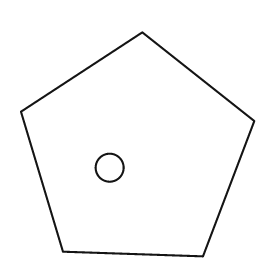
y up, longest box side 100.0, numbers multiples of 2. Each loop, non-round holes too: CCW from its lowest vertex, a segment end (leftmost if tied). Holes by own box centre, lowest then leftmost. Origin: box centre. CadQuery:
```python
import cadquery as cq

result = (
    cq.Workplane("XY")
    .moveTo(28.0, -48.0)
    .lineTo(50.0, 10.0)
    .lineTo(2.0, 48.0)
    .lineTo(-50.0, 14.0)
    .lineTo(-32.0, -46.0)
    .close()
    .moveTo(-12.0, -10.0)
    .circle(6.0)
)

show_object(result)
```